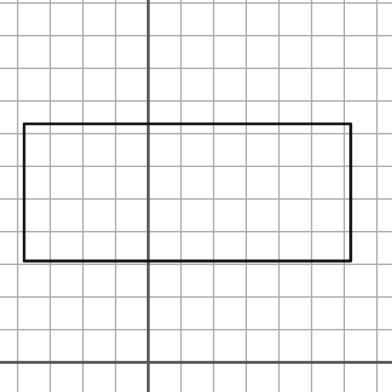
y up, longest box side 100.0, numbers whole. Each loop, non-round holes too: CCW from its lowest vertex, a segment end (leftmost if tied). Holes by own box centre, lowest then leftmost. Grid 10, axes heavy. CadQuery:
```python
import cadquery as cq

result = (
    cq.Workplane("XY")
    .moveTo(-38.0, 31.0)
    .lineTo(62.0, 31.0)
    .lineTo(62.0, 73.0)
    .lineTo(-38.0, 73.0)
    .close()
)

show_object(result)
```